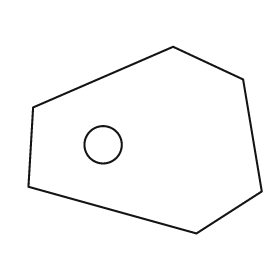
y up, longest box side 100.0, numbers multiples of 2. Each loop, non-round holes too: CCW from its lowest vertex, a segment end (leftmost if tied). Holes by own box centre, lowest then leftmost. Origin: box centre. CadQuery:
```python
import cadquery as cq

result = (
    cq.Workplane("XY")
    .moveTo(22.0, -40.0)
    .lineTo(50.0, -22.0)
    .lineTo(42.0, 26.0)
    .lineTo(12.0, 40.0)
    .lineTo(-48.0, 14.0)
    .lineTo(-50.0, -20.0)
    .close()
    .moveTo(-18.0, -2.0)
    .circle(8.0)
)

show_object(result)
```